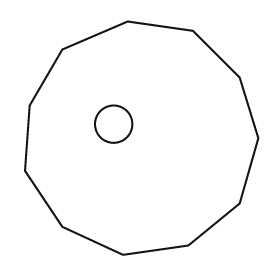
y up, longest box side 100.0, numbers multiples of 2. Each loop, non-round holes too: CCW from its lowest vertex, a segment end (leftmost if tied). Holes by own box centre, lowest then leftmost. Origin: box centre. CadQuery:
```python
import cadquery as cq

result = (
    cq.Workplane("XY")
    .moveTo(-8.0, -50.0)
    .lineTo(20.0, -46.0)
    .lineTo(42.0, -28.0)
    .lineTo(50.0, 0.0)
    .lineTo(42.0, 26.0)
    .lineTo(22.0, 46.0)
    .lineTo(-6.0, 50.0)
    .lineTo(-34.0, 38.0)
    .lineTo(-48.0, 14.0)
    .lineTo(-50.0, -14.0)
    .lineTo(-34.0, -38.0)
    .close()
    .moveTo(-12.0, 6.0)
    .circle(8.0)
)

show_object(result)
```